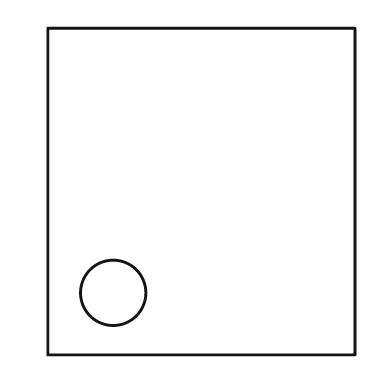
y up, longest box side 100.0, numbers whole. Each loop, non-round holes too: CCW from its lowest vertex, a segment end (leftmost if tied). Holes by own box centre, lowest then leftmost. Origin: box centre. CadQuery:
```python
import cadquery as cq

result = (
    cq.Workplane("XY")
    .moveTo(-47.0, -50.0)
    .lineTo(47.0, -50.0)
    .lineTo(47.0, 50.0)
    .lineTo(-47.0, 50.0)
    .close()
    .moveTo(-27.0, -31.0)
    .circle(10.0)
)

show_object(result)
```